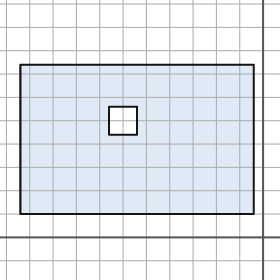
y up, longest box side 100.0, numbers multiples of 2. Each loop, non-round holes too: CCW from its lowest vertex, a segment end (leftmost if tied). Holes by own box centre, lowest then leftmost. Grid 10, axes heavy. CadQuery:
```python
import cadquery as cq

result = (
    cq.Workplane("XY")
    .moveTo(-104.0, 10.0)
    .lineTo(-4.0, 10.0)
    .lineTo(-4.0, 74.0)
    .lineTo(-104.0, 74.0)
    .close()
    .moveTo(-66.0, 44.0)
    .lineTo(-54.0, 44.0)
    .lineTo(-54.0, 56.0)
    .lineTo(-66.0, 56.0)
    .close()
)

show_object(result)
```